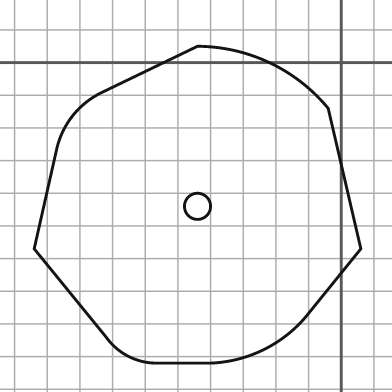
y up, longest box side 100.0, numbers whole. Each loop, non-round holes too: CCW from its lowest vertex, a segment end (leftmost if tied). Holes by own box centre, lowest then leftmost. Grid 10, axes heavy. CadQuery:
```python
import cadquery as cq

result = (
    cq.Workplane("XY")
    .moveTo(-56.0, -92.0)
    .lineTo(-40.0, -92.0)
    .threePointArc((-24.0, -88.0), (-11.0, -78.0))
    .lineTo(6.0, -57.0)
    .lineTo(-4.0, -14.0)
    .threePointArc((-22.0, 0.0), (-44.0, 5.0))
    .lineTo(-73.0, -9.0)
    .threePointArc((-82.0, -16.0), (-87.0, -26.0))
    .lineTo(-94.0, -57.0)
    .lineTo(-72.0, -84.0)
    .threePointArc((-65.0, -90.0), (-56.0, -92.0))
    .close()
    .moveTo(-44.0, -44.0)
    .circle(4.0)
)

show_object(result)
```